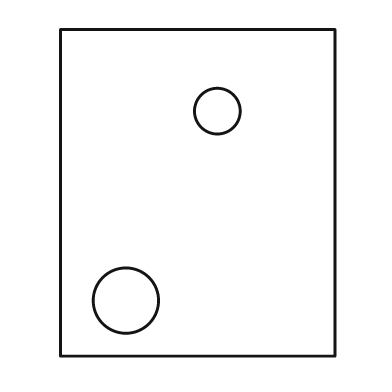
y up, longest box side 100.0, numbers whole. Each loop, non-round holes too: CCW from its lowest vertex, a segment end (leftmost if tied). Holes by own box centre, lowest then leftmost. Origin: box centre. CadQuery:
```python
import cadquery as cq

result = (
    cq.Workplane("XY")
    .moveTo(-42.0, -50.0)
    .lineTo(42.0, -50.0)
    .lineTo(42.0, 50.0)
    .lineTo(-42.0, 50.0)
    .close()
    .moveTo(-22.0, -33.0)
    .circle(10.0)
    .moveTo(6.0, 25.0)
    .circle(7.0)
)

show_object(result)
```